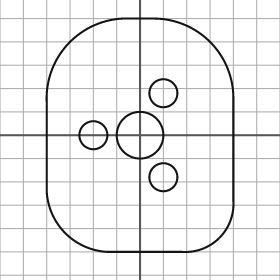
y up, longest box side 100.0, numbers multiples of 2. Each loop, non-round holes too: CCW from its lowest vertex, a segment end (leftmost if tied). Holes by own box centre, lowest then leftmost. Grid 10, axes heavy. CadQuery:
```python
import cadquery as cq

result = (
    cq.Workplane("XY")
    .moveTo(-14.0, -50.0)
    .lineTo(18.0, -50.0)
    .threePointArc((34.0, -44.0), (40.0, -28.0))
    .lineTo(40.0, 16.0)
    .threePointArc((30.0, 40.0), (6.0, 50.0))
    .lineTo(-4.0, 50.0)
    .threePointArc((-30.0, 40.0), (-40.0, 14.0))
    .lineTo(-40.0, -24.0)
    .threePointArc((-32.0, -42.0), (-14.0, -50.0))
    .close()
    .moveTo(10.0, -18.0)
    .circle(6.0)
    .moveTo(-20.0, 0.0)
    .circle(6.0)
    .moveTo(0.0, 0.0)
    .circle(10.0)
    .moveTo(10.0, 18.0)
    .circle(6.0)
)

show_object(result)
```